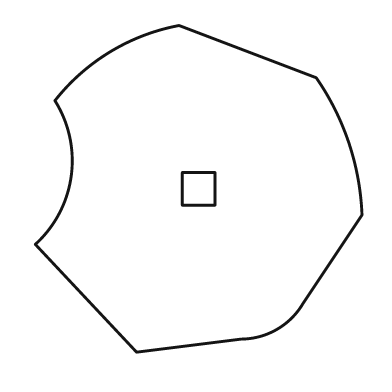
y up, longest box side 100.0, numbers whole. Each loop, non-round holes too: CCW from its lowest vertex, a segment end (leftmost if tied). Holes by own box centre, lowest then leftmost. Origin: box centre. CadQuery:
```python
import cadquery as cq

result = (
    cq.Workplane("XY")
    .moveTo(-19.0, -50.0)
    .lineTo(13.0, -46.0)
    .threePointArc((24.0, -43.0), (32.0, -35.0))
    .lineTo(50.0, -8.0)
    .threePointArc((46.0, 14.0), (36.0, 34.0))
    .lineTo(-6.0, 50.0)
    .threePointArc((-27.0, 42.0), (-44.0, 27.0))
    .threePointArc((-39.0, 4.0), (-50.0, -17.0))
    .close()
    .moveTo(-5.0, -5.0)
    .lineTo(5.0, -5.0)
    .lineTo(5.0, 5.0)
    .lineTo(-5.0, 5.0)
    .close()
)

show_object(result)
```